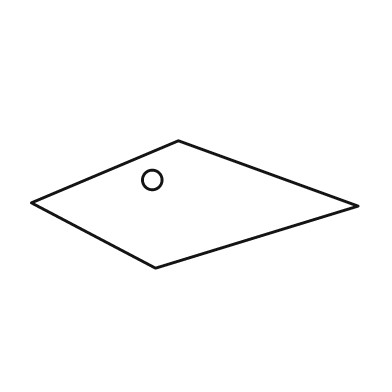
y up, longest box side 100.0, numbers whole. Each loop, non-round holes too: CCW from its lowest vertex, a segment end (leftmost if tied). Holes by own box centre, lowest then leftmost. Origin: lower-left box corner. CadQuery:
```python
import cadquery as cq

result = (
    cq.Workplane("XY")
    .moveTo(38.0, 0.0)
    .lineTo(100.0, 19.0)
    .lineTo(45.0, 39.0)
    .lineTo(0.0, 20.0)
    .close()
    .moveTo(37.0, 27.0)
    .circle(3.0)
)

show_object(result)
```